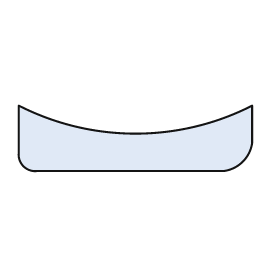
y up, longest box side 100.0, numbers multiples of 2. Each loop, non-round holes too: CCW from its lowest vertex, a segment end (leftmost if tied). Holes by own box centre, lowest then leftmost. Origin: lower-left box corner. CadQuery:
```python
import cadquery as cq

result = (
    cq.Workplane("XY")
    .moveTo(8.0, 0.0)
    .lineTo(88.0, 0.0)
    .threePointArc((96.0, 4.0), (100.0, 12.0))
    .lineTo(100.0, 28.0)
    .threePointArc((50.0, 16.0), (0.0, 28.0))
    .lineTo(0.0, 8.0)
    .threePointArc((2.0, 2.0), (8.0, 0.0))
    .close()
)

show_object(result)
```